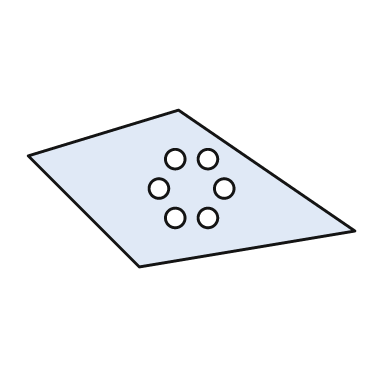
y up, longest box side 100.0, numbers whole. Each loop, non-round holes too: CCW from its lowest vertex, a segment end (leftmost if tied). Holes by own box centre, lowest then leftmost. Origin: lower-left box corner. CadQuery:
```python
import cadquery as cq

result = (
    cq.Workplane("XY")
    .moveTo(34.0, 0.0)
    .lineTo(100.0, 11.0)
    .lineTo(46.0, 48.0)
    .lineTo(0.0, 34.0)
    .close()
    .moveTo(45.0, 15.0)
    .circle(3.0)
    .moveTo(55.0, 15.0)
    .circle(3.0)
    .moveTo(40.0, 24.0)
    .circle(3.0)
    .moveTo(60.0, 24.0)
    .circle(3.0)
    .moveTo(45.0, 33.0)
    .circle(3.0)
    .moveTo(55.0, 33.0)
    .circle(3.0)
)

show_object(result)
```